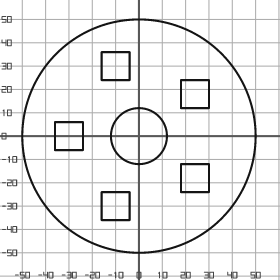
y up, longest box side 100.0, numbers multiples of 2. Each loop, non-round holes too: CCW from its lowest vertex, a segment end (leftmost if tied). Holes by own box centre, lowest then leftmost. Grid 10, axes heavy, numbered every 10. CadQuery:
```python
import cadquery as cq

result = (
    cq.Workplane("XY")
    .moveTo(0.0, 0.0)
    .circle(50.0)
    .moveTo(-16.0, -36.0)
    .lineTo(-4.0, -36.0)
    .lineTo(-4.0, -24.0)
    .lineTo(-16.0, -24.0)
    .close()
    .moveTo(18.0, -24.0)
    .lineTo(30.0, -24.0)
    .lineTo(30.0, -12.0)
    .lineTo(18.0, -12.0)
    .close()
    .moveTo(-36.0, -6.0)
    .lineTo(-24.0, -6.0)
    .lineTo(-24.0, 6.0)
    .lineTo(-36.0, 6.0)
    .close()
    .moveTo(0.0, 0.0)
    .circle(12.0)
    .moveTo(18.0, 12.0)
    .lineTo(30.0, 12.0)
    .lineTo(30.0, 24.0)
    .lineTo(18.0, 24.0)
    .close()
    .moveTo(-16.0, 24.0)
    .lineTo(-4.0, 24.0)
    .lineTo(-4.0, 36.0)
    .lineTo(-16.0, 36.0)
    .close()
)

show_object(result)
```